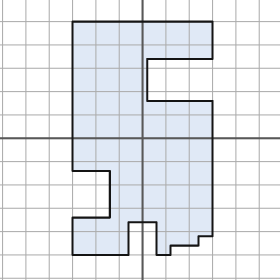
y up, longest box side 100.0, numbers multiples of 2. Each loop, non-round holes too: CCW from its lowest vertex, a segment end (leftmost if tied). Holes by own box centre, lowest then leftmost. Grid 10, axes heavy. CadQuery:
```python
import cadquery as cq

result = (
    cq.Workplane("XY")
    .moveTo(-30.0, -50.0)
    .lineTo(-6.0, -50.0)
    .lineTo(-6.0, -36.0)
    .lineTo(6.0, -36.0)
    .lineTo(6.0, -50.0)
    .lineTo(12.0, -50.0)
    .lineTo(12.0, -46.0)
    .lineTo(24.0, -46.0)
    .lineTo(24.0, -42.0)
    .lineTo(30.0, -42.0)
    .lineTo(30.0, 16.0)
    .lineTo(2.0, 16.0)
    .lineTo(2.0, 34.0)
    .lineTo(30.0, 34.0)
    .lineTo(30.0, 50.0)
    .lineTo(-30.0, 50.0)
    .lineTo(-30.0, -14.0)
    .lineTo(-14.0, -14.0)
    .lineTo(-14.0, -34.0)
    .lineTo(-30.0, -34.0)
    .close()
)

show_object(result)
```